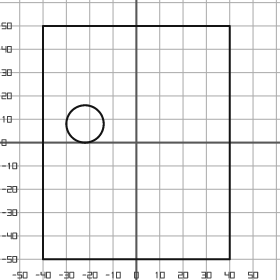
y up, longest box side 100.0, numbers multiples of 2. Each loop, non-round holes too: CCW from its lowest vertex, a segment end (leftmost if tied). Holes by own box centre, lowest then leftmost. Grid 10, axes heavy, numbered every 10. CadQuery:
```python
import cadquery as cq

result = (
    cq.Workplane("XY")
    .moveTo(-40.0, -50.0)
    .lineTo(40.0, -50.0)
    .lineTo(40.0, 50.0)
    .lineTo(-40.0, 50.0)
    .close()
    .moveTo(-22.0, 8.0)
    .circle(8.0)
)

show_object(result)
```